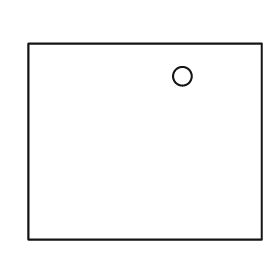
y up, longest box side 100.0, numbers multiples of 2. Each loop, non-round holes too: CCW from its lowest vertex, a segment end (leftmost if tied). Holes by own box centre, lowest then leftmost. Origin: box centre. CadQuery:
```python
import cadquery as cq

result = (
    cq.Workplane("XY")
    .moveTo(-50.0, -42.0)
    .lineTo(50.0, -42.0)
    .lineTo(50.0, 42.0)
    .lineTo(-50.0, 42.0)
    .close()
    .moveTo(16.0, 28.0)
    .circle(4.0)
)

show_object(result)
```